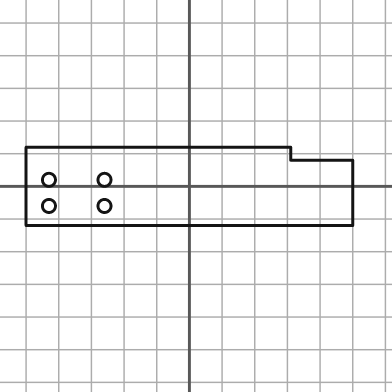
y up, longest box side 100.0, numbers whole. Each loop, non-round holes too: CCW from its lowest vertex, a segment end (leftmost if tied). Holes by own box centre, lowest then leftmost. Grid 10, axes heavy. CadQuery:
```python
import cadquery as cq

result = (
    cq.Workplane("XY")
    .moveTo(-50.0, -12.0)
    .lineTo(50.0, -12.0)
    .lineTo(50.0, 8.0)
    .lineTo(31.0, 8.0)
    .lineTo(31.0, 12.0)
    .lineTo(-50.0, 12.0)
    .close()
    .moveTo(-43.0, -6.0)
    .circle(2.0)
    .moveTo(-26.0, -6.0)
    .circle(2.0)
    .moveTo(-43.0, 2.0)
    .circle(2.0)
    .moveTo(-26.0, 2.0)
    .circle(2.0)
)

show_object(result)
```